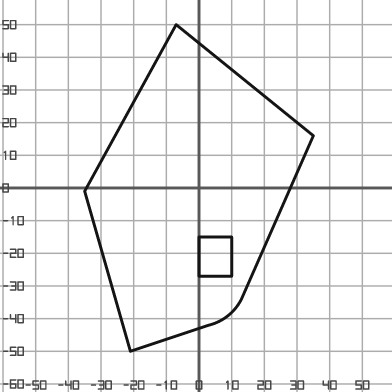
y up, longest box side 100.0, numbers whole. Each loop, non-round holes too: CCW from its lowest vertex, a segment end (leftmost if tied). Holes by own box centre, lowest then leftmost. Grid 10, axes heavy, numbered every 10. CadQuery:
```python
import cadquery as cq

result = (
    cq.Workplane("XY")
    .moveTo(-21.0, -50.0)
    .lineTo(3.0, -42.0)
    .threePointArc((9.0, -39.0), (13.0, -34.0))
    .lineTo(35.0, 16.0)
    .lineTo(-7.0, 50.0)
    .lineTo(-35.0, -1.0)
    .close()
    .moveTo(0.0, -27.0)
    .lineTo(10.0, -27.0)
    .lineTo(10.0, -15.0)
    .lineTo(0.0, -15.0)
    .close()
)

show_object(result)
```